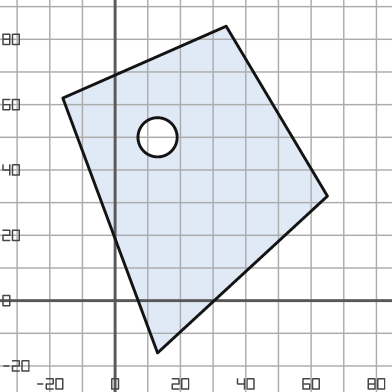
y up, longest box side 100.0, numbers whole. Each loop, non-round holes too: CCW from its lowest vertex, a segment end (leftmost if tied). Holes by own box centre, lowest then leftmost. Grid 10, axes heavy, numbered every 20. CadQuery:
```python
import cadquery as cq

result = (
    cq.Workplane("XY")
    .moveTo(13.0, -16.0)
    .lineTo(65.0, 32.0)
    .lineTo(34.0, 84.0)
    .lineTo(-16.0, 62.0)
    .close()
    .moveTo(13.0, 50.0)
    .circle(6.0)
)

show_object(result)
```